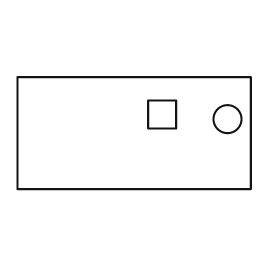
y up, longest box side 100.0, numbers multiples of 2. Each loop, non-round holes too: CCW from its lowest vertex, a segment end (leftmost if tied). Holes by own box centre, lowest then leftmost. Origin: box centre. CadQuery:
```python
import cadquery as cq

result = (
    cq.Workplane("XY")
    .moveTo(-50.0, -24.0)
    .lineTo(50.0, -24.0)
    .lineTo(50.0, 24.0)
    .lineTo(-50.0, 24.0)
    .close()
    .moveTo(40.0, 6.0)
    .circle(6.0)
    .moveTo(6.0, 2.0)
    .lineTo(18.0, 2.0)
    .lineTo(18.0, 14.0)
    .lineTo(6.0, 14.0)
    .close()
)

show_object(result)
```